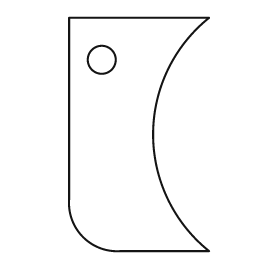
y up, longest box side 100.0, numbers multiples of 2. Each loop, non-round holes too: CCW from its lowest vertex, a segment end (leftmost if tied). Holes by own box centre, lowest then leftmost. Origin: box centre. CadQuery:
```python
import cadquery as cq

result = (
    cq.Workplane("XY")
    .moveTo(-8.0, -50.0)
    .lineTo(30.0, -50.0)
    .threePointArc((6.0, 0.0), (30.0, 50.0))
    .lineTo(-30.0, 50.0)
    .lineTo(-30.0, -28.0)
    .threePointArc((-24.0, -44.0), (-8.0, -50.0))
    .close()
    .moveTo(-16.0, 32.0)
    .circle(6.0)
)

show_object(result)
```